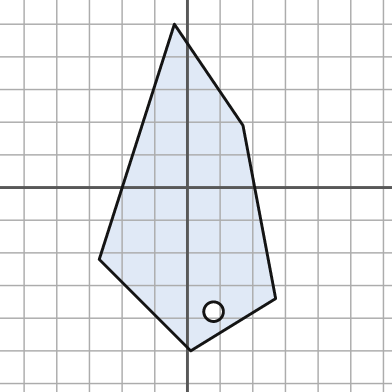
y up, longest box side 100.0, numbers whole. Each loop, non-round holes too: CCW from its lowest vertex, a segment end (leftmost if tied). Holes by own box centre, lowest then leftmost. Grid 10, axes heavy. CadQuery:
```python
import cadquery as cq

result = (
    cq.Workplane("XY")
    .moveTo(1.0, -50.0)
    .lineTo(27.0, -34.0)
    .lineTo(17.0, 19.0)
    .lineTo(-4.0, 50.0)
    .lineTo(-27.0, -22.0)
    .close()
    .moveTo(8.0, -38.0)
    .circle(3.0)
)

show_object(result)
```